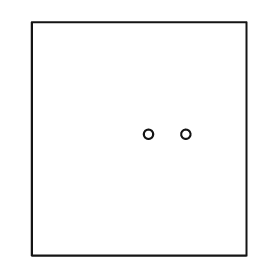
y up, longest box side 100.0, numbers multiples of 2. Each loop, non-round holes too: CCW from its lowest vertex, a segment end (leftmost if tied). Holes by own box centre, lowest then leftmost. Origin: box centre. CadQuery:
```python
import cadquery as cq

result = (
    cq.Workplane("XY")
    .moveTo(-46.0, -50.0)
    .lineTo(46.0, -50.0)
    .lineTo(46.0, 50.0)
    .lineTo(-46.0, 50.0)
    .close()
    .moveTo(4.0, 2.0)
    .circle(2.0)
    .moveTo(20.0, 2.0)
    .circle(2.0)
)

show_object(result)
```